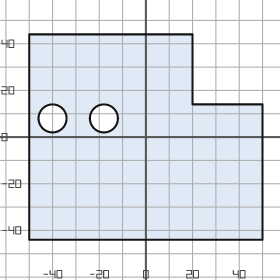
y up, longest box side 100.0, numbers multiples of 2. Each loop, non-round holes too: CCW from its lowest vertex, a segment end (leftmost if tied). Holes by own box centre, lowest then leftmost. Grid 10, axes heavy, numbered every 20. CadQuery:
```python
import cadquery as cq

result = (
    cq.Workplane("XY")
    .moveTo(-50.0, -44.0)
    .lineTo(50.0, -44.0)
    .lineTo(50.0, 14.0)
    .lineTo(20.0, 14.0)
    .lineTo(20.0, 44.0)
    .lineTo(-50.0, 44.0)
    .close()
    .moveTo(-40.0, 8.0)
    .circle(6.0)
    .moveTo(-18.0, 8.0)
    .circle(6.0)
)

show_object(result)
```